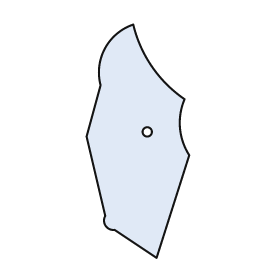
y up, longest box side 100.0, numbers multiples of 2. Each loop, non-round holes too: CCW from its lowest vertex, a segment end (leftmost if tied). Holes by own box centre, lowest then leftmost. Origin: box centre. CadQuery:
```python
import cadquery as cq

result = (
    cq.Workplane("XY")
    .moveTo(8.0, -50.0)
    .lineTo(22.0, -6.0)
    .threePointArc((18.0, 6.0), (20.0, 18.0))
    .threePointArc((6.0, 32.0), (-2.0, 50.0))
    .threePointArc((-14.0, 40.0), (-16.0, 24.0))
    .lineTo(-22.0, 2.0)
    .lineTo(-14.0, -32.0)
    .threePointArc((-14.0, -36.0), (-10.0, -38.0))
    .close()
    .moveTo(4.0, 4.0)
    .circle(2.0)
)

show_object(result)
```